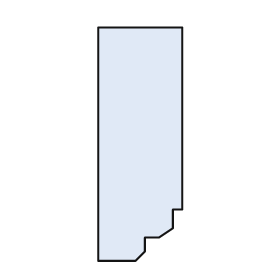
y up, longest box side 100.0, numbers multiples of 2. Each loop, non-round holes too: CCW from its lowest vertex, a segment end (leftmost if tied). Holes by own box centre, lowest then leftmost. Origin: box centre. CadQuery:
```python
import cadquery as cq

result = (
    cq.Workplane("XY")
    .moveTo(-18.0, -50.0)
    .lineTo(-2.0, -50.0)
    .lineTo(2.0, -46.0)
    .lineTo(2.0, -40.0)
    .lineTo(8.0, -40.0)
    .lineTo(14.0, -36.0)
    .lineTo(14.0, -28.0)
    .lineTo(18.0, -28.0)
    .lineTo(18.0, 50.0)
    .lineTo(-18.0, 50.0)
    .close()
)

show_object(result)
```